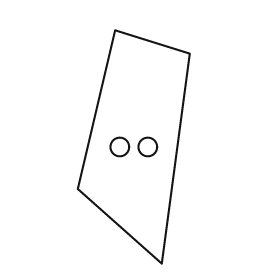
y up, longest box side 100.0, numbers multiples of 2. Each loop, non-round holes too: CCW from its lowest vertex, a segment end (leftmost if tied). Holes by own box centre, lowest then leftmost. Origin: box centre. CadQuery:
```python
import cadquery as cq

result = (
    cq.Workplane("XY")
    .moveTo(12.0, -50.0)
    .lineTo(24.0, 40.0)
    .lineTo(-8.0, 50.0)
    .lineTo(-24.0, -18.0)
    .close()
    .moveTo(-6.0, 0.0)
    .circle(4.0)
    .moveTo(6.0, 0.0)
    .circle(4.0)
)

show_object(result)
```